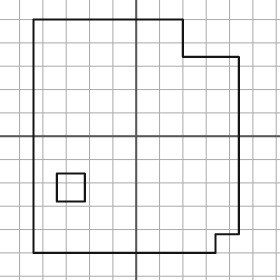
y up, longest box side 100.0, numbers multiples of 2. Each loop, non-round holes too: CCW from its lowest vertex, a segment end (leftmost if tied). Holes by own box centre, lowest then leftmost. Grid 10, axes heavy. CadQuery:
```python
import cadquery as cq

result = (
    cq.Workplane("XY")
    .moveTo(-44.0, -50.0)
    .lineTo(34.0, -50.0)
    .lineTo(34.0, -42.0)
    .lineTo(44.0, -42.0)
    .lineTo(44.0, 34.0)
    .lineTo(20.0, 34.0)
    .lineTo(20.0, 50.0)
    .lineTo(-44.0, 50.0)
    .close()
    .moveTo(-34.0, -28.0)
    .lineTo(-22.0, -28.0)
    .lineTo(-22.0, -16.0)
    .lineTo(-34.0, -16.0)
    .close()
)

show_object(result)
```